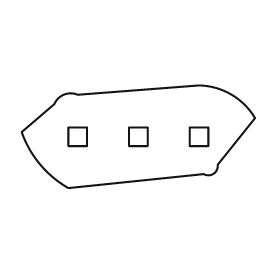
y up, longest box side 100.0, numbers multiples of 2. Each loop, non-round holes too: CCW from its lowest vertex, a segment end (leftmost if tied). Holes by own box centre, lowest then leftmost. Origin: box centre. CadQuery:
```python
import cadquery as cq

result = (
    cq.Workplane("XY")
    .moveTo(-30.0, -22.0)
    .lineTo(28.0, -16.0)
    .threePointArc((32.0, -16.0), (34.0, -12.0))
    .lineTo(50.0, 8.0)
    .threePointArc((40.0, 18.0), (26.0, 22.0))
    .lineTo(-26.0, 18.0)
    .threePointArc((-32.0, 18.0), (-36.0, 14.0))
    .lineTo(-50.0, 2.0)
    .threePointArc((-42.0, -12.0), (-30.0, -22.0))
    .close()
    .moveTo(-30.0, -4.0)
    .lineTo(-22.0, -4.0)
    .lineTo(-22.0, 4.0)
    .lineTo(-30.0, 4.0)
    .close()
    .moveTo(-4.0, -4.0)
    .lineTo(4.0, -4.0)
    .lineTo(4.0, 4.0)
    .lineTo(-4.0, 4.0)
    .close()
    .moveTo(22.0, -4.0)
    .lineTo(30.0, -4.0)
    .lineTo(30.0, 4.0)
    .lineTo(22.0, 4.0)
    .close()
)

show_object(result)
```